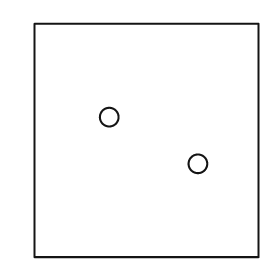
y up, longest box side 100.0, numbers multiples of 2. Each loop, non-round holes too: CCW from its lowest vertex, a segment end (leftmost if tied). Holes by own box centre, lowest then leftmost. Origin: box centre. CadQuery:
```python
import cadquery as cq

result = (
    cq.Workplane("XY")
    .moveTo(-48.0, -50.0)
    .lineTo(48.0, -50.0)
    .lineTo(48.0, 50.0)
    .lineTo(-48.0, 50.0)
    .close()
    .moveTo(22.0, -10.0)
    .circle(4.0)
    .moveTo(-16.0, 10.0)
    .circle(4.0)
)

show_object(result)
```